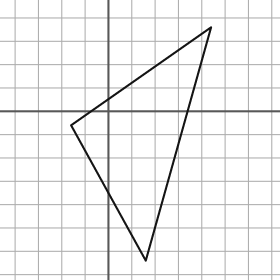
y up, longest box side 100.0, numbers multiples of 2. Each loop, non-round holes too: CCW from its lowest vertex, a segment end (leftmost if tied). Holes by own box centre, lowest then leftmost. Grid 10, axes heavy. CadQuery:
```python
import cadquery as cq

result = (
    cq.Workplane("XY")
    .moveTo(16.0, -64.0)
    .lineTo(44.0, 36.0)
    .lineTo(-16.0, -6.0)
    .close()
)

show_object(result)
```